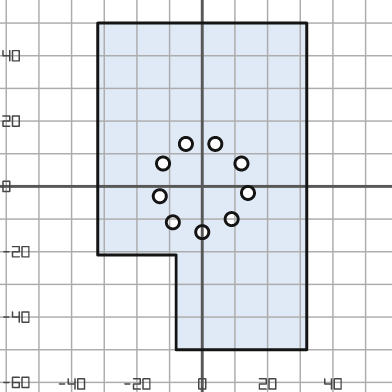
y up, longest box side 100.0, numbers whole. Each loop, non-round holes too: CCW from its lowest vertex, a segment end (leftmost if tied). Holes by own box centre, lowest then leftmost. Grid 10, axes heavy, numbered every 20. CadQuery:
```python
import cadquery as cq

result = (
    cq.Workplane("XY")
    .moveTo(-8.0, -50.0)
    .lineTo(32.0, -50.0)
    .lineTo(32.0, 50.0)
    .lineTo(-32.0, 50.0)
    .lineTo(-32.0, -21.0)
    .lineTo(-8.0, -21.0)
    .close()
    .moveTo(0.0, -14.0)
    .circle(2.0)
    .moveTo(-9.0, -11.0)
    .circle(2.0)
    .moveTo(9.0, -10.0)
    .circle(2.0)
    .moveTo(-13.0, -3.0)
    .circle(2.0)
    .moveTo(14.0, -2.0)
    .circle(2.0)
    .moveTo(-12.0, 7.0)
    .circle(2.0)
    .moveTo(12.0, 7.0)
    .circle(2.0)
    .moveTo(-5.0, 13.0)
    .circle(2.0)
    .moveTo(4.0, 13.0)
    .circle(2.0)
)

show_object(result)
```